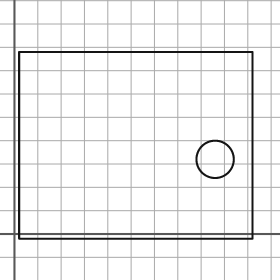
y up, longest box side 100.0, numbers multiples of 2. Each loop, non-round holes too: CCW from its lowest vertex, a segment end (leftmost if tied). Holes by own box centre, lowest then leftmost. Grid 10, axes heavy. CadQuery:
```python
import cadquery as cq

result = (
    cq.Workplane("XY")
    .moveTo(2.0, -2.0)
    .lineTo(102.0, -2.0)
    .lineTo(102.0, 78.0)
    .lineTo(2.0, 78.0)
    .close()
    .moveTo(86.0, 32.0)
    .circle(8.0)
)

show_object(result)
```